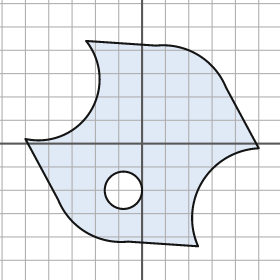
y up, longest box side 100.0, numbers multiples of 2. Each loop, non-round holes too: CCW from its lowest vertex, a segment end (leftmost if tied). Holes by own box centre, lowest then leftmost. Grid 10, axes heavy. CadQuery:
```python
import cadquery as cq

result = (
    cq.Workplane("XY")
    .moveTo(24.0, -44.0)
    .threePointArc((26.0, -16.0), (50.0, -2.0))
    .lineTo(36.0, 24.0)
    .threePointArc((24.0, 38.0), (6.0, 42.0))
    .lineTo(-24.0, 44.0)
    .threePointArc((-22.0, 14.0), (-50.0, 2.0))
    .lineTo(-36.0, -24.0)
    .threePointArc((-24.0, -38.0), (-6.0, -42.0))
    .close()
    .moveTo(-8.0, -20.0)
    .circle(8.0)
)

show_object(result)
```